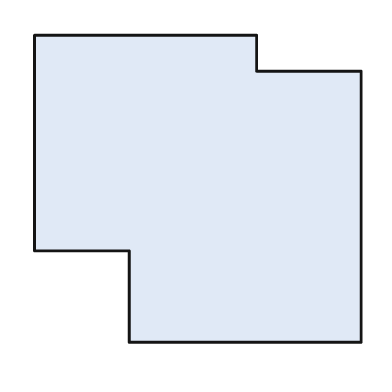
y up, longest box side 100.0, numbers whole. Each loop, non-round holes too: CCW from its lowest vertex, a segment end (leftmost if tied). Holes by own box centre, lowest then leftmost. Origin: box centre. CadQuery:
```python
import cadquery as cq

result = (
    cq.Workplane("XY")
    .moveTo(-21.0, -47.0)
    .lineTo(50.0, -47.0)
    .lineTo(50.0, 36.0)
    .lineTo(18.0, 36.0)
    .lineTo(18.0, 47.0)
    .lineTo(-50.0, 47.0)
    .lineTo(-50.0, -19.0)
    .lineTo(-21.0, -19.0)
    .close()
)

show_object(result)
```